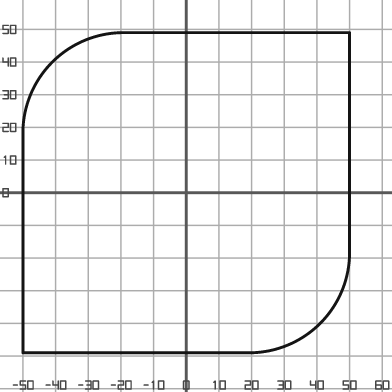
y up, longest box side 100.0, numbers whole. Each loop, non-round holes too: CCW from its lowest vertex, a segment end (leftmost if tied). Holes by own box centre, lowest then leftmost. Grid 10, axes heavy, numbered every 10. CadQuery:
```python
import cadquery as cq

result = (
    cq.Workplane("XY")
    .moveTo(-50.0, -49.0)
    .lineTo(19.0, -49.0)
    .threePointArc((41.0, -40.0), (50.0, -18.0))
    .lineTo(50.0, 49.0)
    .lineTo(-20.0, 49.0)
    .threePointArc((-41.0, 40.0), (-50.0, 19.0))
    .close()
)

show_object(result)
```